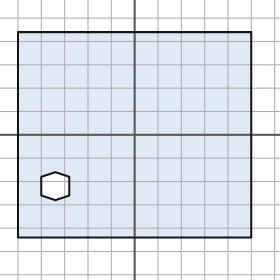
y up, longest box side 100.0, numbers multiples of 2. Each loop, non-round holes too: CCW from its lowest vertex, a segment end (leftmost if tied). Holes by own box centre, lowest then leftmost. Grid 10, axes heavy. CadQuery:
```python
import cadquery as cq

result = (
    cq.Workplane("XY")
    .moveTo(-50.0, -44.0)
    .lineTo(50.0, -44.0)
    .lineTo(50.0, 44.0)
    .lineTo(-50.0, 44.0)
    .close()
    .moveTo(-34.0, -28.0)
    .lineTo(-28.0, -26.0)
    .lineTo(-28.0, -18.0)
    .lineTo(-34.0, -16.0)
    .lineTo(-40.0, -18.0)
    .lineTo(-40.0, -26.0)
    .close()
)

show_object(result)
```